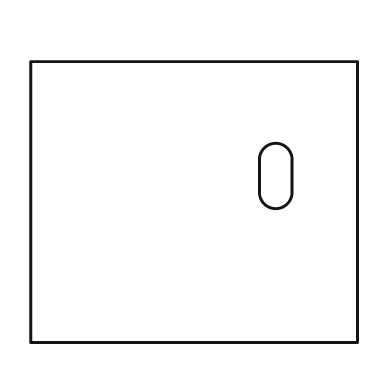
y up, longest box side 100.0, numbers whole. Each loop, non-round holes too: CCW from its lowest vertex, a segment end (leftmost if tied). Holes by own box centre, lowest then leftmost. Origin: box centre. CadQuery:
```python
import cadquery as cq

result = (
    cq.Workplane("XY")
    .moveTo(-50.0, -43.0)
    .lineTo(50.0, -43.0)
    .lineTo(50.0, 43.0)
    .lineTo(-50.0, 43.0)
    .close()
    .moveTo(20.0, 3.0)
    .threePointArc((25.0, -2.0), (30.0, 3.0))
    .lineTo(30.0, 13.0)
    .threePointArc((25.0, 18.0), (20.0, 13.0))
    .close()
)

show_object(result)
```